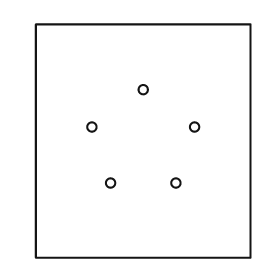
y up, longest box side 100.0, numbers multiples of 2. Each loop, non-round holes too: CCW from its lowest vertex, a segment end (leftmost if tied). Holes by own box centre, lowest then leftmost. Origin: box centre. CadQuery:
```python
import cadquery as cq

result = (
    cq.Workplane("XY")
    .moveTo(-46.0, -50.0)
    .lineTo(46.0, -50.0)
    .lineTo(46.0, 50.0)
    .lineTo(-46.0, 50.0)
    .close()
    .moveTo(-14.0, -18.0)
    .circle(2.0)
    .moveTo(14.0, -18.0)
    .circle(2.0)
    .moveTo(-22.0, 6.0)
    .circle(2.0)
    .moveTo(22.0, 6.0)
    .circle(2.0)
    .moveTo(0.0, 22.0)
    .circle(2.0)
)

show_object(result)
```